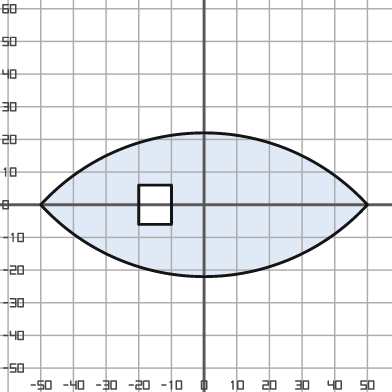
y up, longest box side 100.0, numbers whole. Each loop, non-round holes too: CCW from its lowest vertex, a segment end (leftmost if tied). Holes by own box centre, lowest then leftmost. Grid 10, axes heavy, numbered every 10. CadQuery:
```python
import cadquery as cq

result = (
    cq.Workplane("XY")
    .moveTo(-50.0, 0.0)
    .threePointArc((0.0, -22.0), (50.0, 0.0))
    .threePointArc((0.0, 22.0), (-50.0, 0.0))
    .close()
    .moveTo(-20.0, -6.0)
    .lineTo(-10.0, -6.0)
    .lineTo(-10.0, 6.0)
    .lineTo(-20.0, 6.0)
    .close()
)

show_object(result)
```